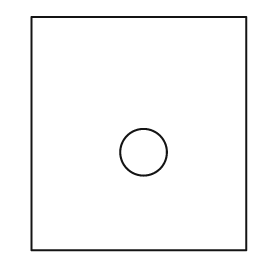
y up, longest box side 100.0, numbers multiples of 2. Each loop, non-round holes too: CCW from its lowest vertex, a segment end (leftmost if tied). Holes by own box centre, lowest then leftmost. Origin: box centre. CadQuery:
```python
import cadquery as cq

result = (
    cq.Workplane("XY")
    .moveTo(-46.0, -50.0)
    .lineTo(46.0, -50.0)
    .lineTo(46.0, 50.0)
    .lineTo(-46.0, 50.0)
    .close()
    .moveTo(2.0, -8.0)
    .circle(10.0)
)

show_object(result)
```